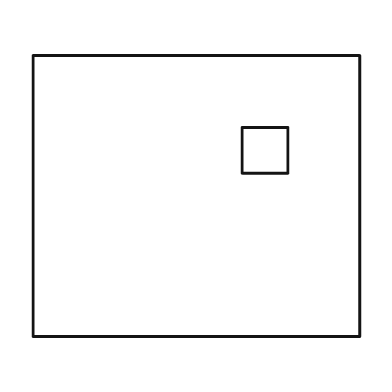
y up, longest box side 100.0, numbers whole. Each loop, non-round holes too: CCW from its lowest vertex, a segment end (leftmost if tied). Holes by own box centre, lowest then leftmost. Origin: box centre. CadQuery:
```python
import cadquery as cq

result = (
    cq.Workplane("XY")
    .moveTo(-50.0, -43.0)
    .lineTo(50.0, -43.0)
    .lineTo(50.0, 43.0)
    .lineTo(-50.0, 43.0)
    .close()
    .moveTo(14.0, 7.0)
    .lineTo(28.0, 7.0)
    .lineTo(28.0, 21.0)
    .lineTo(14.0, 21.0)
    .close()
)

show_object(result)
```